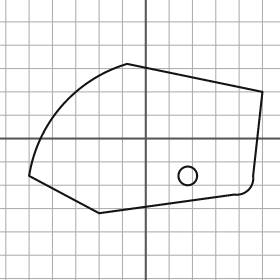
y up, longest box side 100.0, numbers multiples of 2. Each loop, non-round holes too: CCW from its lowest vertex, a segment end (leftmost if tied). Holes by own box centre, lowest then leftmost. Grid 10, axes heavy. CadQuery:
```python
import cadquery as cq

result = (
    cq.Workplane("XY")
    .moveTo(-20.0, -32.0)
    .lineTo(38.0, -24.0)
    .threePointArc((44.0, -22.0), (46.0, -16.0))
    .lineTo(50.0, 20.0)
    .lineTo(-8.0, 32.0)
    .threePointArc((-36.0, 14.0), (-50.0, -16.0))
    .close()
    .moveTo(18.0, -16.0)
    .circle(4.0)
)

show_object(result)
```